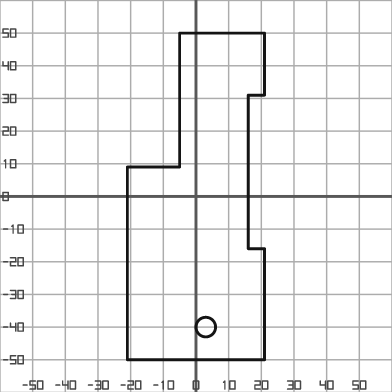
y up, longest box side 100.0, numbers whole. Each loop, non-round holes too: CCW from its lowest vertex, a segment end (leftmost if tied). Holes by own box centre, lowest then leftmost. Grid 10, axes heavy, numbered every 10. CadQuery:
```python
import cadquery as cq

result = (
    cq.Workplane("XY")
    .moveTo(-21.0, -50.0)
    .lineTo(21.0, -50.0)
    .lineTo(21.0, -16.0)
    .lineTo(16.0, -16.0)
    .lineTo(16.0, 31.0)
    .lineTo(21.0, 31.0)
    .lineTo(21.0, 50.0)
    .lineTo(-5.0, 50.0)
    .lineTo(-5.0, 9.0)
    .lineTo(-21.0, 9.0)
    .close()
    .moveTo(3.0, -40.0)
    .circle(3.0)
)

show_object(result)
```